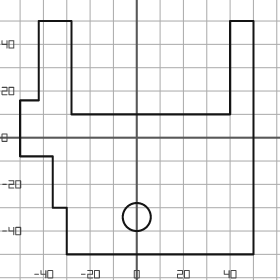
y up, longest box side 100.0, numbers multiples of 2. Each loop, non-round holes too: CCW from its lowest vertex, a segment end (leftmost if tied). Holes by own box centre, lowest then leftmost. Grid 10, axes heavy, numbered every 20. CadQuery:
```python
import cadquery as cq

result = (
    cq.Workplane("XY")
    .moveTo(-30.0, -50.0)
    .lineTo(50.0, -50.0)
    .lineTo(50.0, 50.0)
    .lineTo(40.0, 50.0)
    .lineTo(40.0, 10.0)
    .lineTo(-28.0, 10.0)
    .lineTo(-28.0, 50.0)
    .lineTo(-42.0, 50.0)
    .lineTo(-42.0, 16.0)
    .lineTo(-50.0, 16.0)
    .lineTo(-50.0, -8.0)
    .lineTo(-36.0, -8.0)
    .lineTo(-36.0, -30.0)
    .lineTo(-30.0, -30.0)
    .close()
    .moveTo(0.0, -34.0)
    .circle(6.0)
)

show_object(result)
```